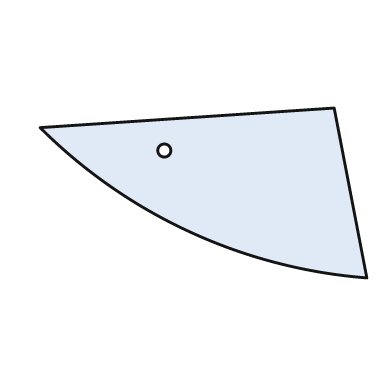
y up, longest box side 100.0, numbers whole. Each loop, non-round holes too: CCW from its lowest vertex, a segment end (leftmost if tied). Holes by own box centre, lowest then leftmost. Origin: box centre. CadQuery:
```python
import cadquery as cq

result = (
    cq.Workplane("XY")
    .moveTo(50.0, -26.0)
    .lineTo(40.0, 26.0)
    .lineTo(-50.0, 20.0)
    .threePointArc((-4.0, -12.0), (50.0, -26.0))
    .close()
    .moveTo(-12.0, 13.0)
    .circle(2.0)
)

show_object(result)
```